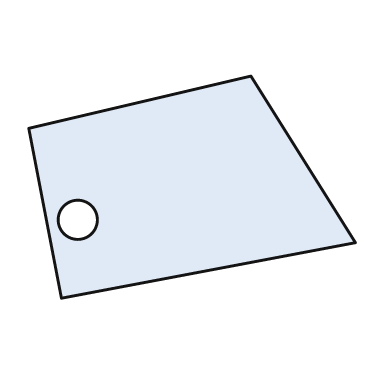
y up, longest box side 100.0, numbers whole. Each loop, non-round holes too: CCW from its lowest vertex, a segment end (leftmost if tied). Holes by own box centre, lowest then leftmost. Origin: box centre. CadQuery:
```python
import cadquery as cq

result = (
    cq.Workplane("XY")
    .moveTo(-40.0, -34.0)
    .lineTo(50.0, -17.0)
    .lineTo(18.0, 34.0)
    .lineTo(-50.0, 18.0)
    .close()
    .moveTo(-35.0, -10.0)
    .circle(6.0)
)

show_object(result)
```